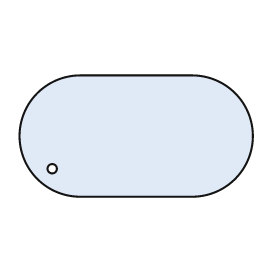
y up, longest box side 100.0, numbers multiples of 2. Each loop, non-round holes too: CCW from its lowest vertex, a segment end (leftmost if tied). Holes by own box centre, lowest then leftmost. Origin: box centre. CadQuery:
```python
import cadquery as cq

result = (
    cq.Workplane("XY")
    .moveTo(-24.0, -26.0)
    .lineTo(24.0, -26.0)
    .threePointArc((50.0, 0.0), (24.0, 26.0))
    .lineTo(-24.0, 26.0)
    .threePointArc((-50.0, 0.0), (-24.0, -26.0))
    .close()
    .moveTo(-36.0, -14.0)
    .circle(2.0)
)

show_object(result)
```